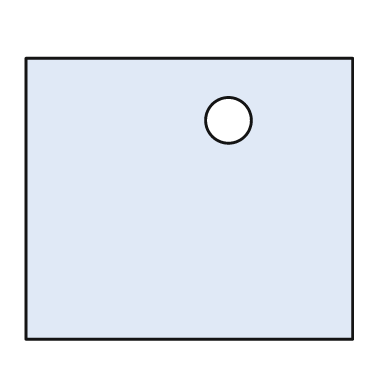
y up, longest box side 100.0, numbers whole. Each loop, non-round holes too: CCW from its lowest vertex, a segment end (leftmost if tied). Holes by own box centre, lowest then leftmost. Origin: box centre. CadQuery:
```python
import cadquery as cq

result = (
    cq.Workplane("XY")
    .moveTo(-50.0, -43.0)
    .lineTo(50.0, -43.0)
    .lineTo(50.0, 43.0)
    .lineTo(-50.0, 43.0)
    .close()
    .moveTo(12.0, 24.0)
    .circle(7.0)
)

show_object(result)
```